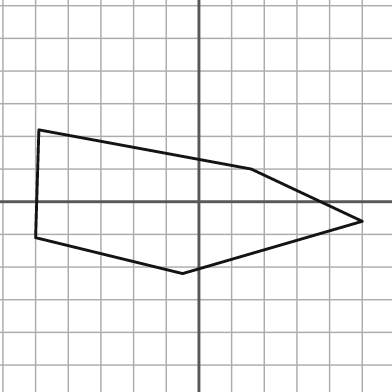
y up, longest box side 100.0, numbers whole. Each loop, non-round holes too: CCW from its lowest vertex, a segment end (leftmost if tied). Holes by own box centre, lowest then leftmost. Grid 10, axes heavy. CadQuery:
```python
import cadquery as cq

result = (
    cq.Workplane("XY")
    .moveTo(-5.0, -22.0)
    .lineTo(50.0, -6.0)
    .lineTo(16.0, 10.0)
    .lineTo(-49.0, 22.0)
    .lineTo(-50.0, -11.0)
    .close()
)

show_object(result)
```